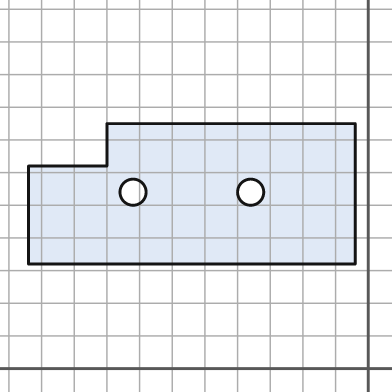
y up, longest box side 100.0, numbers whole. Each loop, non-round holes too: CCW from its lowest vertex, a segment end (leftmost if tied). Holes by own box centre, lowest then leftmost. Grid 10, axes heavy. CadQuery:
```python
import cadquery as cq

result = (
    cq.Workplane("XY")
    .moveTo(-104.0, 32.0)
    .lineTo(-4.0, 32.0)
    .lineTo(-4.0, 75.0)
    .lineTo(-80.0, 75.0)
    .lineTo(-80.0, 62.0)
    .lineTo(-104.0, 62.0)
    .close()
    .moveTo(-72.0, 54.0)
    .circle(4.0)
    .moveTo(-36.0, 54.0)
    .circle(4.0)
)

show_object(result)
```